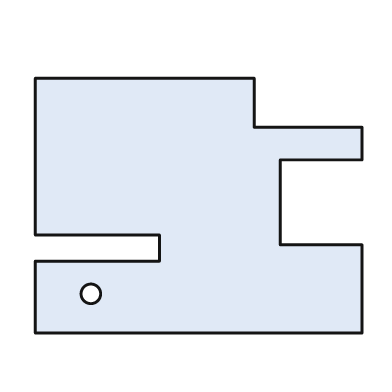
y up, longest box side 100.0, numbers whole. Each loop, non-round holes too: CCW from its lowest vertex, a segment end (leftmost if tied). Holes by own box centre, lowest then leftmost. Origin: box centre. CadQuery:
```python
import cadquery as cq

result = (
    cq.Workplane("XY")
    .moveTo(-50.0, -39.0)
    .lineTo(50.0, -39.0)
    .lineTo(50.0, -12.0)
    .lineTo(25.0, -12.0)
    .lineTo(25.0, 14.0)
    .lineTo(50.0, 14.0)
    .lineTo(50.0, 24.0)
    .lineTo(17.0, 24.0)
    .lineTo(17.0, 39.0)
    .lineTo(-50.0, 39.0)
    .lineTo(-50.0, -9.0)
    .lineTo(-12.0, -9.0)
    .lineTo(-12.0, -17.0)
    .lineTo(-50.0, -17.0)
    .close()
    .moveTo(-33.0, -27.0)
    .circle(3.0)
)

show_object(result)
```